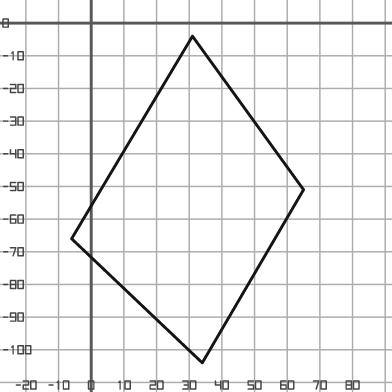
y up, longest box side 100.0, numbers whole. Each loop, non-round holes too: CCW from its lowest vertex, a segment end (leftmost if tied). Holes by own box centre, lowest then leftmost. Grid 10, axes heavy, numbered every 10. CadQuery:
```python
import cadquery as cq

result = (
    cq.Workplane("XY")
    .moveTo(34.0, -104.0)
    .lineTo(65.0, -51.0)
    .lineTo(31.0, -4.0)
    .lineTo(-6.0, -66.0)
    .close()
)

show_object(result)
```